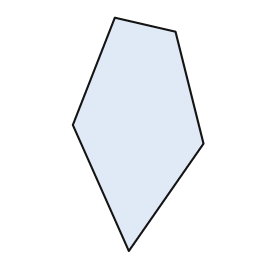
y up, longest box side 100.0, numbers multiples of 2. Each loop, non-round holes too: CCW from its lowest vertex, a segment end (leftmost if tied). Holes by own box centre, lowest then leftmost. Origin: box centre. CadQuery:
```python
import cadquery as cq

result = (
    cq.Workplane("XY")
    .moveTo(-4.0, -50.0)
    .lineTo(28.0, -4.0)
    .lineTo(16.0, 44.0)
    .lineTo(-10.0, 50.0)
    .lineTo(-28.0, 4.0)
    .close()
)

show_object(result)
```